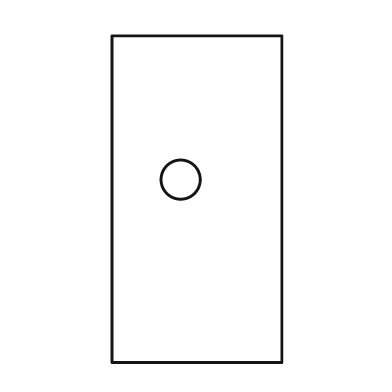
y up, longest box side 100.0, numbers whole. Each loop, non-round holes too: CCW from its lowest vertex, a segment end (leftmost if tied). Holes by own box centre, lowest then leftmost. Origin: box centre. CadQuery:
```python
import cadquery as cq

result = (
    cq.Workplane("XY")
    .moveTo(-26.0, -50.0)
    .lineTo(26.0, -50.0)
    .lineTo(26.0, 50.0)
    .lineTo(-26.0, 50.0)
    .close()
    .moveTo(-5.0, 6.0)
    .circle(6.0)
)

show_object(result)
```